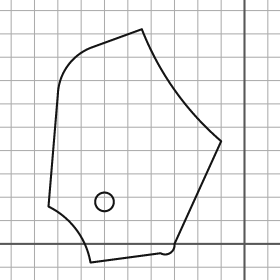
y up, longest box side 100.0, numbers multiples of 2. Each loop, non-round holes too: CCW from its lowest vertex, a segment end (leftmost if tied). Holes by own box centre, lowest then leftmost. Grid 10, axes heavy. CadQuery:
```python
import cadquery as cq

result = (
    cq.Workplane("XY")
    .moveTo(-66.0, -8.0)
    .lineTo(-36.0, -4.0)
    .threePointArc((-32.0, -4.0), (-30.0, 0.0))
    .lineTo(-10.0, 44.0)
    .threePointArc((-30.0, 66.0), (-44.0, 92.0))
    .lineTo(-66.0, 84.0)
    .threePointArc((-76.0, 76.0), (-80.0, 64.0))
    .lineTo(-84.0, 16.0)
    .threePointArc((-72.0, 6.0), (-66.0, -8.0))
    .close()
    .moveTo(-60.0, 18.0)
    .circle(4.0)
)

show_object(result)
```